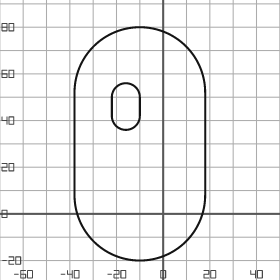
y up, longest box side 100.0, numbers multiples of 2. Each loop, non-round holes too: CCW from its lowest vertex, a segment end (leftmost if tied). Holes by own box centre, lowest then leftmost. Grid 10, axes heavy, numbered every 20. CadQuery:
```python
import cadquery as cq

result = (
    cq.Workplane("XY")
    .moveTo(-38.0, 8.0)
    .threePointArc((-10.0, -20.0), (18.0, 8.0))
    .lineTo(18.0, 52.0)
    .threePointArc((-10.0, 80.0), (-38.0, 52.0))
    .close()
    .moveTo(-22.0, 42.0)
    .threePointArc((-16.0, 36.0), (-10.0, 42.0))
    .lineTo(-10.0, 50.0)
    .threePointArc((-16.0, 56.0), (-22.0, 50.0))
    .close()
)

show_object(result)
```